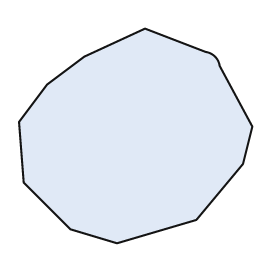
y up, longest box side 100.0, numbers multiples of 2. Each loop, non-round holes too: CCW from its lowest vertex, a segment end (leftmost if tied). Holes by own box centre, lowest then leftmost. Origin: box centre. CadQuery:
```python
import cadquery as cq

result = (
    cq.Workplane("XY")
    .moveTo(-8.0, -46.0)
    .lineTo(26.0, -36.0)
    .lineTo(46.0, -12.0)
    .lineTo(50.0, 4.0)
    .lineTo(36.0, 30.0)
    .threePointArc((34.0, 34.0), (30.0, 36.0))
    .lineTo(4.0, 46.0)
    .lineTo(-22.0, 34.0)
    .lineTo(-38.0, 22.0)
    .lineTo(-50.0, 6.0)
    .lineTo(-48.0, -20.0)
    .lineTo(-28.0, -40.0)
    .close()
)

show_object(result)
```